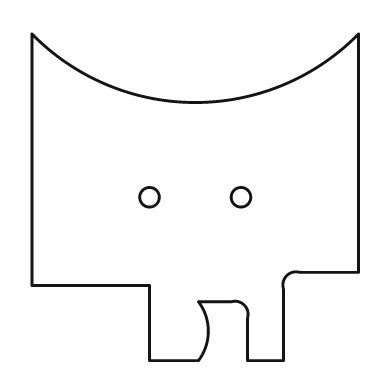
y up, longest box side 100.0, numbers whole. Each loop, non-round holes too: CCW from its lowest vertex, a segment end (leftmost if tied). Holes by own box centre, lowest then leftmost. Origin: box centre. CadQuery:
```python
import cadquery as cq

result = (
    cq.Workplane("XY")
    .moveTo(-14.0, -50.0)
    .lineTo(1.0, -50.0)
    .threePointArc((4.0, -41.0), (1.0, -32.0))
    .lineTo(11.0, -32.0)
    .threePointArc((15.0, -33.0), (16.0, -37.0))
    .lineTo(16.0, -50.0)
    .lineTo(27.0, -50.0)
    .lineTo(27.0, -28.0)
    .threePointArc((28.0, -24.0), (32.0, -23.0))
    .lineTo(50.0, -23.0)
    .lineTo(50.0, 50.0)
    .threePointArc((0.0, 29.0), (-50.0, 50.0))
    .lineTo(-50.0, -27.0)
    .lineTo(-14.0, -27.0)
    .close()
    .moveTo(-14.0, 0.0)
    .circle(3.0)
    .moveTo(14.0, 0.0)
    .circle(3.0)
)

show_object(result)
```